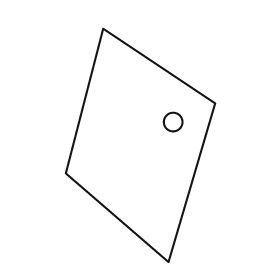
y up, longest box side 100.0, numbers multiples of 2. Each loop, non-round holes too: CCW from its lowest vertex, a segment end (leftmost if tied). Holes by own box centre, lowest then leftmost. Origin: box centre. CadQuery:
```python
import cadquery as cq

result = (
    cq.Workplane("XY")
    .moveTo(12.0, -50.0)
    .lineTo(32.0, 18.0)
    .lineTo(-16.0, 50.0)
    .lineTo(-32.0, -12.0)
    .close()
    .moveTo(14.0, 10.0)
    .circle(4.0)
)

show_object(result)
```